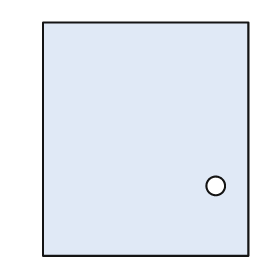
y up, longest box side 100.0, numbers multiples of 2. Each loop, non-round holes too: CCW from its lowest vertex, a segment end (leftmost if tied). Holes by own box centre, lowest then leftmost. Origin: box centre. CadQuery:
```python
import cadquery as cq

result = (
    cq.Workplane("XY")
    .moveTo(-44.0, -50.0)
    .lineTo(44.0, -50.0)
    .lineTo(44.0, 50.0)
    .lineTo(-44.0, 50.0)
    .close()
    .moveTo(30.0, -20.0)
    .circle(4.0)
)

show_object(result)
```